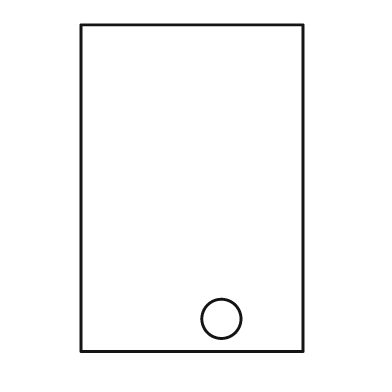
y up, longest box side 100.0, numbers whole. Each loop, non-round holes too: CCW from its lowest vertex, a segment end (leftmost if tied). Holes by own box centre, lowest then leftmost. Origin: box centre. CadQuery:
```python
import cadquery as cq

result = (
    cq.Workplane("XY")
    .moveTo(-34.0, -50.0)
    .lineTo(34.0, -50.0)
    .lineTo(34.0, 50.0)
    .lineTo(-34.0, 50.0)
    .close()
    .moveTo(9.0, -40.0)
    .circle(6.0)
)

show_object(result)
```